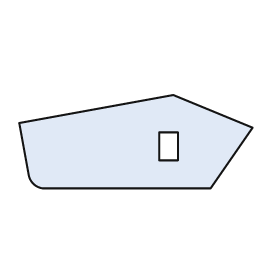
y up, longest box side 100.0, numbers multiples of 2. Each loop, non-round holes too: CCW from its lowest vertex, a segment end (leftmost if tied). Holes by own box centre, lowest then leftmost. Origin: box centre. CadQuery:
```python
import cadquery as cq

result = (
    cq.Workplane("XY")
    .moveTo(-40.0, -20.0)
    .lineTo(32.0, -20.0)
    .lineTo(50.0, 6.0)
    .lineTo(16.0, 20.0)
    .lineTo(-50.0, 8.0)
    .lineTo(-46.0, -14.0)
    .threePointArc((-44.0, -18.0), (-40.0, -20.0))
    .close()
    .moveTo(10.0, -8.0)
    .lineTo(18.0, -8.0)
    .lineTo(18.0, 4.0)
    .lineTo(10.0, 4.0)
    .close()
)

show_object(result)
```